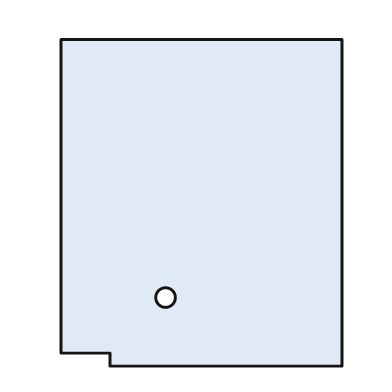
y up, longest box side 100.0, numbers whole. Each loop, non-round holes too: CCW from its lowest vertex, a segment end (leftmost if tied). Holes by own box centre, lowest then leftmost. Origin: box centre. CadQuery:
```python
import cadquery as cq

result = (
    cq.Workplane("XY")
    .moveTo(-28.0, -50.0)
    .lineTo(43.0, -50.0)
    .lineTo(43.0, 50.0)
    .lineTo(-43.0, 50.0)
    .lineTo(-43.0, -46.0)
    .lineTo(-28.0, -46.0)
    .close()
    .moveTo(-11.0, -29.0)
    .circle(3.0)
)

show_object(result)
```